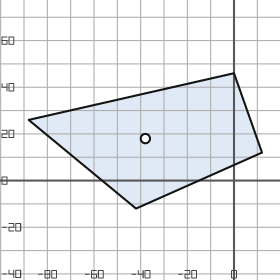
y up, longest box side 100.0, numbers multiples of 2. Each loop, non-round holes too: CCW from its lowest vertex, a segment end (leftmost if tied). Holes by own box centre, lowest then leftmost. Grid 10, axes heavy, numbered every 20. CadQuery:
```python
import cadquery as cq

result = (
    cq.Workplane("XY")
    .moveTo(-42.0, -12.0)
    .lineTo(12.0, 12.0)
    .lineTo(0.0, 46.0)
    .lineTo(-88.0, 26.0)
    .close()
    .moveTo(-38.0, 18.0)
    .circle(2.0)
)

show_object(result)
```